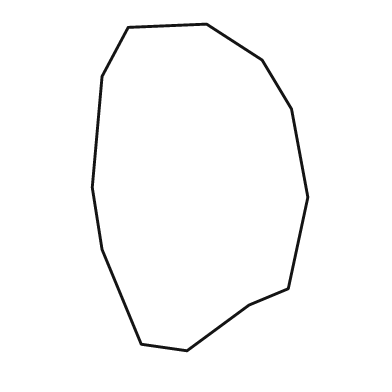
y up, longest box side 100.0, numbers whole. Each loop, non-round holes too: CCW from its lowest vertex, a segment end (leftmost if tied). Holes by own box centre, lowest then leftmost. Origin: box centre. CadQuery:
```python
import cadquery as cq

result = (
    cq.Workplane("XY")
    .moveTo(-4.0, -50.0)
    .lineTo(15.0, -36.0)
    .lineTo(27.0, -31.0)
    .lineTo(33.0, -3.0)
    .lineTo(28.0, 24.0)
    .lineTo(19.0, 39.0)
    .lineTo(2.0, 50.0)
    .lineTo(-22.0, 49.0)
    .lineTo(-30.0, 34.0)
    .lineTo(-33.0, 0.0)
    .lineTo(-30.0, -19.0)
    .lineTo(-18.0, -48.0)
    .close()
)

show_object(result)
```